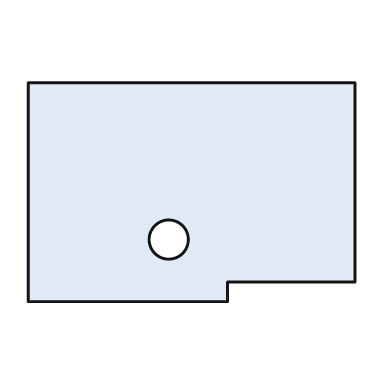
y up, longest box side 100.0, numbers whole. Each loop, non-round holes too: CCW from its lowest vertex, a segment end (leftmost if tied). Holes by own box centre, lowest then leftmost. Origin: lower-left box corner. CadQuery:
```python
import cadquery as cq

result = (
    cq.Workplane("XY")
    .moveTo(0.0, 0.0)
    .lineTo(61.0, 0.0)
    .lineTo(61.0, 6.0)
    .lineTo(100.0, 6.0)
    .lineTo(100.0, 67.0)
    .lineTo(0.0, 67.0)
    .close()
    .moveTo(43.0, 19.0)
    .circle(6.0)
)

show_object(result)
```